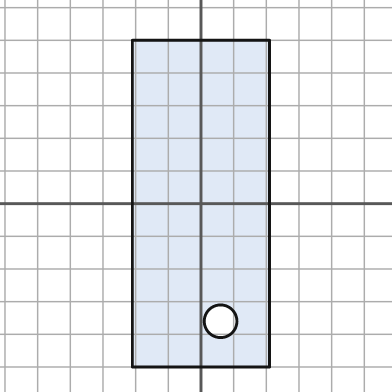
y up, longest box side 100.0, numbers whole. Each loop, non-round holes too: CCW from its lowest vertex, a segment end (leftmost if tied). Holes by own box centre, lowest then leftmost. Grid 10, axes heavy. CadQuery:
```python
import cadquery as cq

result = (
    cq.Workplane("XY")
    .moveTo(-21.0, -50.0)
    .lineTo(21.0, -50.0)
    .lineTo(21.0, 50.0)
    .lineTo(-21.0, 50.0)
    .close()
    .moveTo(6.0, -36.0)
    .circle(5.0)
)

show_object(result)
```